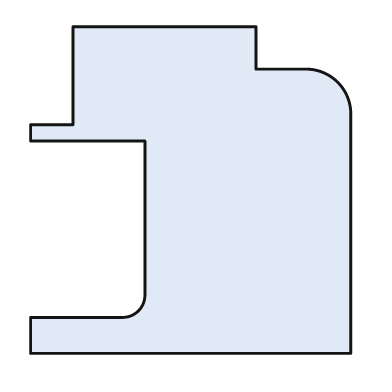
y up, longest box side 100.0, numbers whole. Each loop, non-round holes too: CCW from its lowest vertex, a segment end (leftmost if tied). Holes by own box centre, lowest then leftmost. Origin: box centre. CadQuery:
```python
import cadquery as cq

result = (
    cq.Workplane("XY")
    .moveTo(-49.0, -50.0)
    .lineTo(49.0, -50.0)
    .lineTo(49.0, 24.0)
    .threePointArc((45.0, 33.0), (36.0, 37.0))
    .lineTo(20.0, 37.0)
    .lineTo(20.0, 50.0)
    .lineTo(-36.0, 50.0)
    .lineTo(-36.0, 20.0)
    .lineTo(-49.0, 20.0)
    .lineTo(-49.0, 15.0)
    .lineTo(-14.0, 15.0)
    .lineTo(-14.0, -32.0)
    .threePointArc((-16.0, -37.0), (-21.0, -39.0))
    .lineTo(-49.0, -39.0)
    .close()
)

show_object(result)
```